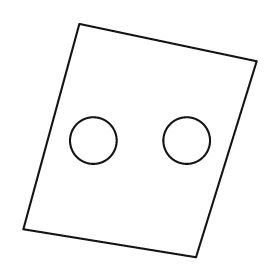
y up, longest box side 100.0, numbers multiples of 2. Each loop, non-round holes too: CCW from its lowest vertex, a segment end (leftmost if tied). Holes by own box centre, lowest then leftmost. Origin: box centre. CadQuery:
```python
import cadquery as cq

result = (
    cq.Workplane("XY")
    .moveTo(24.0, -50.0)
    .lineTo(50.0, 34.0)
    .lineTo(-26.0, 50.0)
    .lineTo(-50.0, -38.0)
    .close()
    .moveTo(-20.0, 0.0)
    .circle(10.0)
    .moveTo(20.0, 0.0)
    .circle(10.0)
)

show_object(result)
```